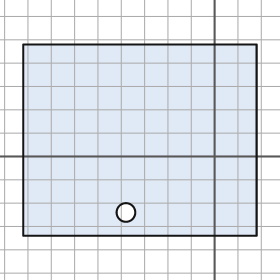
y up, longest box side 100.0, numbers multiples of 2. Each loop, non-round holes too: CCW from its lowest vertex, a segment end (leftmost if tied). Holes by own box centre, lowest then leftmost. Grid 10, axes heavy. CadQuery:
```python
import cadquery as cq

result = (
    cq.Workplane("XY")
    .moveTo(-82.0, -34.0)
    .lineTo(18.0, -34.0)
    .lineTo(18.0, 48.0)
    .lineTo(-82.0, 48.0)
    .close()
    .moveTo(-38.0, -24.0)
    .circle(4.0)
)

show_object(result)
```